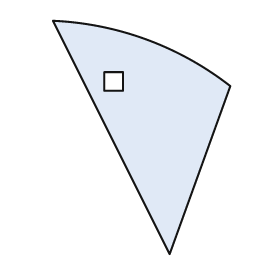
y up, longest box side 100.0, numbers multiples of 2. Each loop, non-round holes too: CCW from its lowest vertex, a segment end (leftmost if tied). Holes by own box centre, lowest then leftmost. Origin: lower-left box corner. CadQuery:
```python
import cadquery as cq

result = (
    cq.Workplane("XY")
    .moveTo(50.0, 0.0)
    .lineTo(76.0, 72.0)
    .threePointArc((40.0, 92.0), (0.0, 100.0))
    .close()
    .moveTo(22.0, 70.0)
    .lineTo(30.0, 70.0)
    .lineTo(30.0, 78.0)
    .lineTo(22.0, 78.0)
    .close()
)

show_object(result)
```